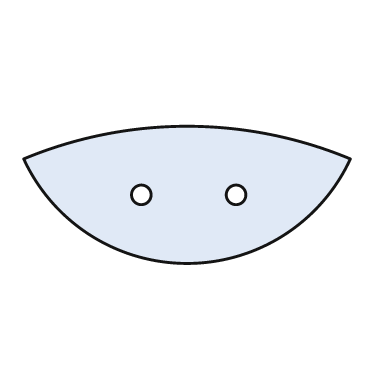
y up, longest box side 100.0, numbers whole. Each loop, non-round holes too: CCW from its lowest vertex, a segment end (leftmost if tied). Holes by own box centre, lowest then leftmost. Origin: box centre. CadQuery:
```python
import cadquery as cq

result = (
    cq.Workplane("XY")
    .moveTo(-50.0, 11.0)
    .threePointArc((0.0, -21.0), (50.0, 11.0))
    .threePointArc((0.0, 21.0), (-50.0, 11.0))
    .close()
    .moveTo(-14.0, 0.0)
    .circle(3.0)
    .moveTo(15.0, 0.0)
    .circle(3.0)
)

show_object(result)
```